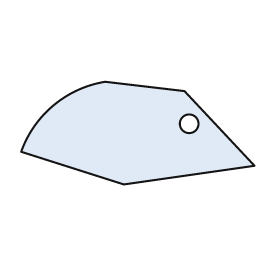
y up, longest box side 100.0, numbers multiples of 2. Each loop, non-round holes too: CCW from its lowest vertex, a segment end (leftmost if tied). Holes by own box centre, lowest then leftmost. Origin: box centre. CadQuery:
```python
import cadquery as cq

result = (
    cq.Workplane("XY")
    .moveTo(-6.0, -22.0)
    .lineTo(50.0, -14.0)
    .lineTo(20.0, 18.0)
    .lineTo(-14.0, 22.0)
    .threePointArc((-36.0, 12.0), (-50.0, -8.0))
    .close()
    .moveTo(22.0, 4.0)
    .circle(4.0)
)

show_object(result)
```